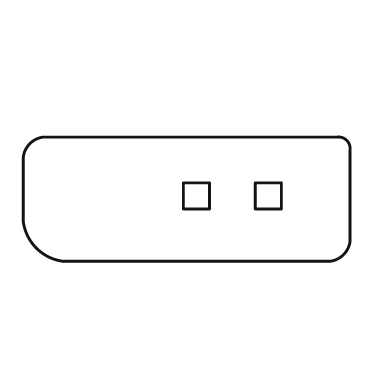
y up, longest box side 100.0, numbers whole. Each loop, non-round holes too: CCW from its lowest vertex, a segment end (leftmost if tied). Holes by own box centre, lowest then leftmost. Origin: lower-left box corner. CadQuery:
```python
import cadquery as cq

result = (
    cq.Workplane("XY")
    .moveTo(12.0, 0.0)
    .lineTo(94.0, 0.0)
    .threePointArc((98.0, 2.0), (100.0, 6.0))
    .lineTo(100.0, 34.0)
    .threePointArc((99.0, 37.0), (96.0, 38.0))
    .lineTo(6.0, 38.0)
    .threePointArc((2.0, 36.0), (0.0, 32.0))
    .lineTo(0.0, 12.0)
    .threePointArc((4.0, 4.0), (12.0, 0.0))
    .close()
    .moveTo(49.0, 16.0)
    .lineTo(57.0, 16.0)
    .lineTo(57.0, 24.0)
    .lineTo(49.0, 24.0)
    .close()
    .moveTo(71.0, 16.0)
    .lineTo(79.0, 16.0)
    .lineTo(79.0, 24.0)
    .lineTo(71.0, 24.0)
    .close()
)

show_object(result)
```